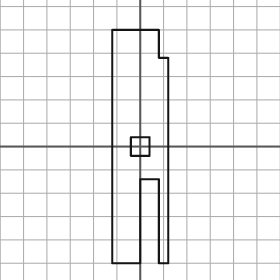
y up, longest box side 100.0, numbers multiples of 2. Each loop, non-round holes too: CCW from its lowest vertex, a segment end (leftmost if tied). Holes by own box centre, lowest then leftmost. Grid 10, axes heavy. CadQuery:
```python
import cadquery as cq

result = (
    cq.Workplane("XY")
    .moveTo(-12.0, -50.0)
    .lineTo(0.0, -50.0)
    .lineTo(0.0, -14.0)
    .lineTo(8.0, -14.0)
    .lineTo(8.0, -50.0)
    .lineTo(12.0, -50.0)
    .lineTo(12.0, 38.0)
    .lineTo(8.0, 38.0)
    .lineTo(8.0, 50.0)
    .lineTo(-12.0, 50.0)
    .close()
    .moveTo(-4.0, -4.0)
    .lineTo(4.0, -4.0)
    .lineTo(4.0, 4.0)
    .lineTo(-4.0, 4.0)
    .close()
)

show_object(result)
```